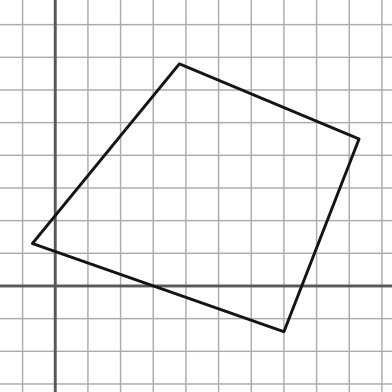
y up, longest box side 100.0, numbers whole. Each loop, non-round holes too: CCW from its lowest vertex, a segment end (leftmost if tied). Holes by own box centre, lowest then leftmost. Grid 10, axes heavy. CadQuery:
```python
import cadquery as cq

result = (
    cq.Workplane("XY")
    .moveTo(70.0, -14.0)
    .lineTo(93.0, 45.0)
    .lineTo(38.0, 68.0)
    .lineTo(-7.0, 13.0)
    .close()
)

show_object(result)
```